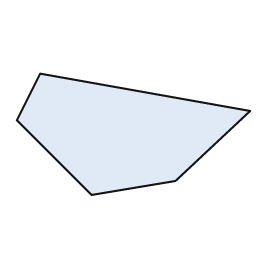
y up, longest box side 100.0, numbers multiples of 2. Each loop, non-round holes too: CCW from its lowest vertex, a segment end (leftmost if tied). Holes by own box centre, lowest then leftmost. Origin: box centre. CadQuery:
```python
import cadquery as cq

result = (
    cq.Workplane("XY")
    .moveTo(-18.0, -26.0)
    .lineTo(18.0, -20.0)
    .lineTo(50.0, 10.0)
    .lineTo(-40.0, 26.0)
    .lineTo(-50.0, 6.0)
    .close()
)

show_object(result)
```